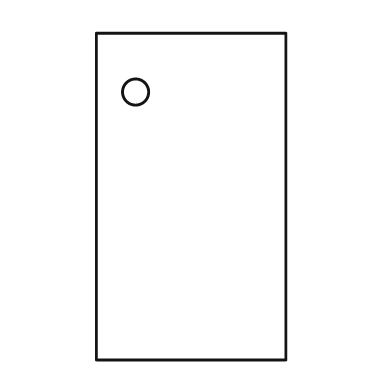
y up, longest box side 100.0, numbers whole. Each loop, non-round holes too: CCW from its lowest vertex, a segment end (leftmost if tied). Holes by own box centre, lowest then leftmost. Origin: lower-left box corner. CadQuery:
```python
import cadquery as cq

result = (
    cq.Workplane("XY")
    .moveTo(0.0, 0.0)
    .lineTo(58.0, 0.0)
    .lineTo(58.0, 100.0)
    .lineTo(0.0, 100.0)
    .close()
    .moveTo(12.0, 82.0)
    .circle(4.0)
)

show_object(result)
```